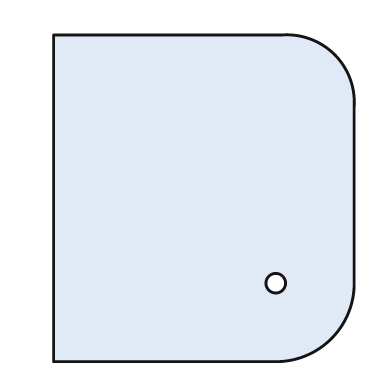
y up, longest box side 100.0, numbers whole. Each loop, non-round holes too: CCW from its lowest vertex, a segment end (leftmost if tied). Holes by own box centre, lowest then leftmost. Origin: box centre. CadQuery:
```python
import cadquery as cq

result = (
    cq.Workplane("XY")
    .moveTo(-46.0, -50.0)
    .lineTo(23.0, -50.0)
    .threePointArc((39.0, -43.0), (46.0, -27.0))
    .lineTo(46.0, 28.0)
    .threePointArc((40.0, 44.0), (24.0, 50.0))
    .lineTo(-46.0, 50.0)
    .close()
    .moveTo(22.0, -26.0)
    .circle(3.0)
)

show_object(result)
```